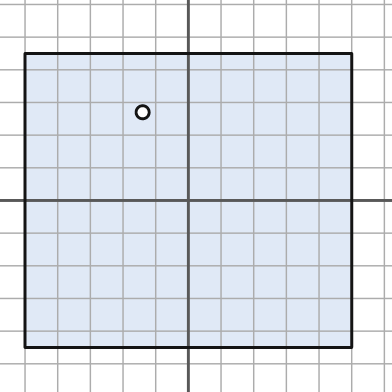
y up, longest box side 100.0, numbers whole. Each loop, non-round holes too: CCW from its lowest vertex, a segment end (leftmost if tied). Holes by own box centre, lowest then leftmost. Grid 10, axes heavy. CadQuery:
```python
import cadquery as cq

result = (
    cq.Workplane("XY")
    .moveTo(-50.0, -45.0)
    .lineTo(50.0, -45.0)
    .lineTo(50.0, 45.0)
    .lineTo(-50.0, 45.0)
    .close()
    .moveTo(-14.0, 27.0)
    .circle(2.0)
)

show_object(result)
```